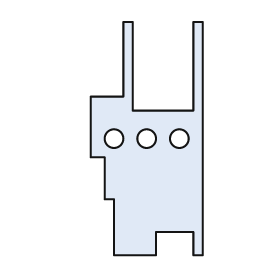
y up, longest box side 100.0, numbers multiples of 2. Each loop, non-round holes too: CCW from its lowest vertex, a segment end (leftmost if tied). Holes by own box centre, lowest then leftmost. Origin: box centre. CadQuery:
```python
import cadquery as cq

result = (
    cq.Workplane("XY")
    .moveTo(-14.0, -50.0)
    .lineTo(4.0, -50.0)
    .lineTo(4.0, -40.0)
    .lineTo(20.0, -40.0)
    .lineTo(20.0, -50.0)
    .lineTo(24.0, -50.0)
    .lineTo(24.0, 50.0)
    .lineTo(20.0, 50.0)
    .lineTo(20.0, 12.0)
    .lineTo(-6.0, 12.0)
    .lineTo(-6.0, 50.0)
    .lineTo(-10.0, 50.0)
    .lineTo(-10.0, 18.0)
    .lineTo(-24.0, 18.0)
    .lineTo(-24.0, -8.0)
    .lineTo(-18.0, -8.0)
    .lineTo(-18.0, -26.0)
    .lineTo(-14.0, -26.0)
    .close()
    .moveTo(-14.0, 0.0)
    .circle(4.0)
    .moveTo(0.0, 0.0)
    .circle(4.0)
    .moveTo(14.0, 0.0)
    .circle(4.0)
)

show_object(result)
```